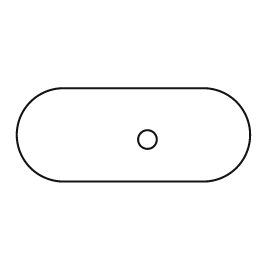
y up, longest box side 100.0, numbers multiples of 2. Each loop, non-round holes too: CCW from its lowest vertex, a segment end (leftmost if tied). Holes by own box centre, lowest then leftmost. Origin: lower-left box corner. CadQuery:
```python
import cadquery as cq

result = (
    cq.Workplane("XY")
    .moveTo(20.0, 0.0)
    .lineTo(80.0, 0.0)
    .threePointArc((100.0, 20.0), (80.0, 40.0))
    .lineTo(20.0, 40.0)
    .threePointArc((0.0, 20.0), (20.0, 0.0))
    .close()
    .moveTo(56.0, 18.0)
    .circle(4.0)
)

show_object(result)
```